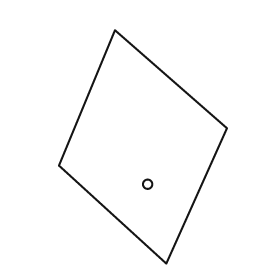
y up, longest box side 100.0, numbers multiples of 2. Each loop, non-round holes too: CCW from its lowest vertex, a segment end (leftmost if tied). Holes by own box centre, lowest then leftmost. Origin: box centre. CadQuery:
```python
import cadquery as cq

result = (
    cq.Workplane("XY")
    .moveTo(10.0, -50.0)
    .lineTo(36.0, 8.0)
    .lineTo(-12.0, 50.0)
    .lineTo(-36.0, -8.0)
    .close()
    .moveTo(2.0, -16.0)
    .circle(2.0)
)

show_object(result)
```